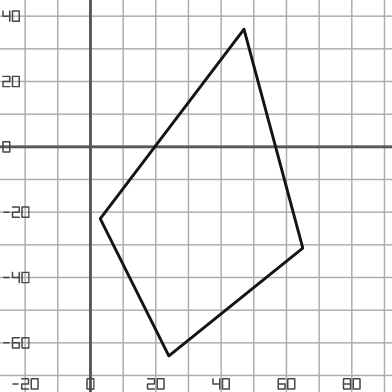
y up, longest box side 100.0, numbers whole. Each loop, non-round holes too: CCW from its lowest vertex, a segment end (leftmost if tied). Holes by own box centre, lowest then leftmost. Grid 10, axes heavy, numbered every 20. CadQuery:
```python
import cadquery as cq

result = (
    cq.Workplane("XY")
    .moveTo(24.0, -64.0)
    .lineTo(65.0, -31.0)
    .lineTo(47.0, 36.0)
    .lineTo(3.0, -22.0)
    .close()
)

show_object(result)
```